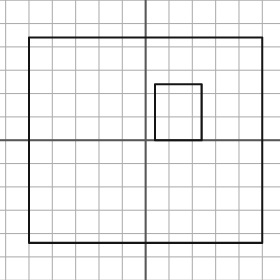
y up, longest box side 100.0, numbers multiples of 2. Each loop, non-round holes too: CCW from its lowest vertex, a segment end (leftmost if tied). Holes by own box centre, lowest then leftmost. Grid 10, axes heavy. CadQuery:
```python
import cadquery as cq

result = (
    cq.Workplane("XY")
    .moveTo(-50.0, -44.0)
    .lineTo(50.0, -44.0)
    .lineTo(50.0, 44.0)
    .lineTo(-50.0, 44.0)
    .close()
    .moveTo(4.0, 0.0)
    .lineTo(24.0, 0.0)
    .lineTo(24.0, 24.0)
    .lineTo(4.0, 24.0)
    .close()
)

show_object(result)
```